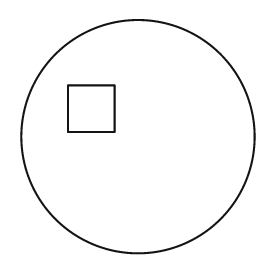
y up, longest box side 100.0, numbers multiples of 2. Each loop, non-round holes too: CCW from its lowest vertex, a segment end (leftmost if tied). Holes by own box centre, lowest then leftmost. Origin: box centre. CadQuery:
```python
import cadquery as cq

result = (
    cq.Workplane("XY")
    .moveTo(0.0, 0.0)
    .circle(50.0)
    .moveTo(-30.0, 2.0)
    .lineTo(-10.0, 2.0)
    .lineTo(-10.0, 22.0)
    .lineTo(-30.0, 22.0)
    .close()
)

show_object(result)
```